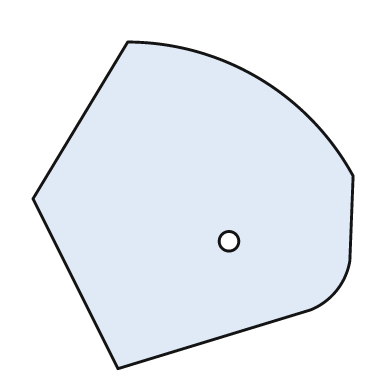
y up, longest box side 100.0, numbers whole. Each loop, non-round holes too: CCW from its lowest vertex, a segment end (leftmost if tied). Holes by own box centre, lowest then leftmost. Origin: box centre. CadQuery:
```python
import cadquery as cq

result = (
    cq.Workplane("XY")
    .moveTo(-23.0, -50.0)
    .lineTo(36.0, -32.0)
    .threePointArc((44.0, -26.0), (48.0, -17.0))
    .lineTo(49.0, 9.0)
    .threePointArc((20.0, 39.0), (-20.0, 50.0))
    .lineTo(-49.0, 2.0)
    .close()
    .moveTo(11.0, -11.0)
    .circle(3.0)
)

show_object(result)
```